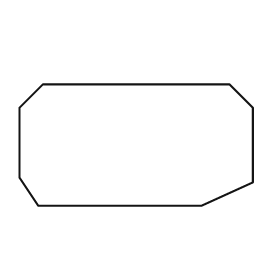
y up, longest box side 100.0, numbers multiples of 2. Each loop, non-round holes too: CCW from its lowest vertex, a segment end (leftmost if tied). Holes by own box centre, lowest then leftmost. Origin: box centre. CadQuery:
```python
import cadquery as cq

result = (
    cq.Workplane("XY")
    .moveTo(-42.0, -26.0)
    .lineTo(28.0, -26.0)
    .lineTo(50.0, -16.0)
    .lineTo(50.0, 16.0)
    .lineTo(40.0, 26.0)
    .lineTo(-40.0, 26.0)
    .lineTo(-50.0, 16.0)
    .lineTo(-50.0, -14.0)
    .close()
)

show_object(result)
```